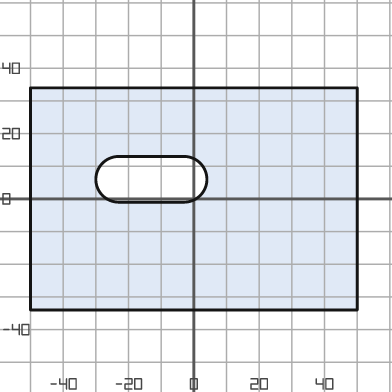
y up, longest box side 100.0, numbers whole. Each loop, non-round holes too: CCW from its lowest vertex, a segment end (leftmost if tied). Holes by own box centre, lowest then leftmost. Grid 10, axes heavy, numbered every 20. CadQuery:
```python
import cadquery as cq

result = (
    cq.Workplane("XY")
    .moveTo(-50.0, -34.0)
    .lineTo(50.0, -34.0)
    .lineTo(50.0, 34.0)
    .lineTo(-50.0, 34.0)
    .close()
    .moveTo(-23.0, -1.0)
    .lineTo(-3.0, -1.0)
    .threePointArc((4.0, 6.0), (-3.0, 13.0))
    .lineTo(-23.0, 13.0)
    .threePointArc((-30.0, 6.0), (-23.0, -1.0))
    .close()
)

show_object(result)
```